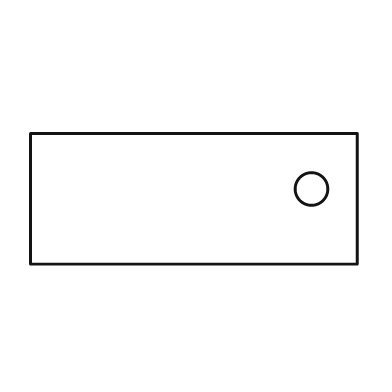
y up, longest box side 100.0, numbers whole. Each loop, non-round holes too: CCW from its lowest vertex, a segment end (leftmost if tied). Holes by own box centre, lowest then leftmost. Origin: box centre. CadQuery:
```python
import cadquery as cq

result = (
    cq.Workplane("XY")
    .moveTo(-50.0, -20.0)
    .lineTo(50.0, -20.0)
    .lineTo(50.0, 20.0)
    .lineTo(-50.0, 20.0)
    .close()
    .moveTo(36.0, 3.0)
    .circle(5.0)
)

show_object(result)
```